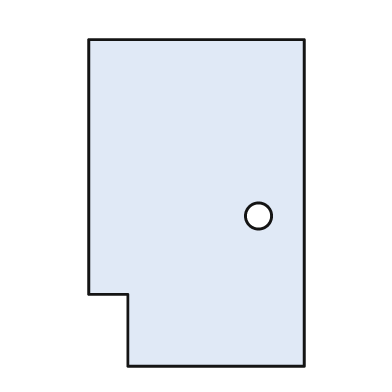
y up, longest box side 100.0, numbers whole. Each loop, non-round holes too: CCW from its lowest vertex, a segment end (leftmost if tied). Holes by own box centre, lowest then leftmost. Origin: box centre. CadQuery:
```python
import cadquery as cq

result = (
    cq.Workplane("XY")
    .moveTo(-21.0, -50.0)
    .lineTo(33.0, -50.0)
    .lineTo(33.0, 50.0)
    .lineTo(-33.0, 50.0)
    .lineTo(-33.0, -28.0)
    .lineTo(-21.0, -28.0)
    .close()
    .moveTo(19.0, -4.0)
    .circle(4.0)
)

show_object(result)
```